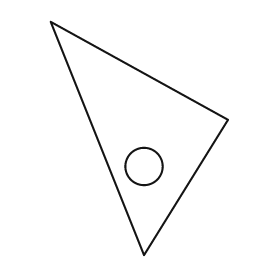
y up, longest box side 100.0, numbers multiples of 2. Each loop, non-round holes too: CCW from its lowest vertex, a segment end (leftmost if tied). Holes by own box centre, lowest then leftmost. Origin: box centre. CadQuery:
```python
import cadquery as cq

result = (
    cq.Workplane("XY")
    .moveTo(2.0, -50.0)
    .lineTo(38.0, 8.0)
    .lineTo(-38.0, 50.0)
    .close()
    .moveTo(2.0, -12.0)
    .circle(8.0)
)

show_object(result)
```